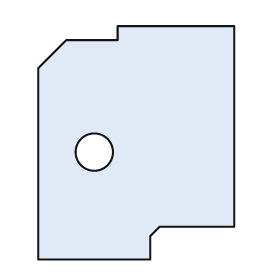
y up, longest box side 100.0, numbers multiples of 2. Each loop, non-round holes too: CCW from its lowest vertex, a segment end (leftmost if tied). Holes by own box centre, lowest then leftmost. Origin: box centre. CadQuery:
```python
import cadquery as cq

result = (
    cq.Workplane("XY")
    .moveTo(-42.0, -50.0)
    .lineTo(6.0, -50.0)
    .lineTo(6.0, -40.0)
    .lineTo(10.0, -36.0)
    .lineTo(42.0, -36.0)
    .lineTo(42.0, 50.0)
    .lineTo(-8.0, 50.0)
    .lineTo(-8.0, 44.0)
    .lineTo(-30.0, 44.0)
    .lineTo(-42.0, 32.0)
    .close()
    .moveTo(-18.0, -4.0)
    .circle(8.0)
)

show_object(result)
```